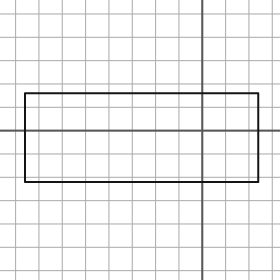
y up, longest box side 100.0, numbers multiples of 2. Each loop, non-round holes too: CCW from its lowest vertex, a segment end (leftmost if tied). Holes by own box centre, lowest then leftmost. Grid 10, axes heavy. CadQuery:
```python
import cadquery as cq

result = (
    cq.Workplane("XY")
    .moveTo(-76.0, -22.0)
    .lineTo(24.0, -22.0)
    .lineTo(24.0, 16.0)
    .lineTo(-76.0, 16.0)
    .close()
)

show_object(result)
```